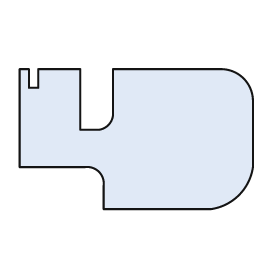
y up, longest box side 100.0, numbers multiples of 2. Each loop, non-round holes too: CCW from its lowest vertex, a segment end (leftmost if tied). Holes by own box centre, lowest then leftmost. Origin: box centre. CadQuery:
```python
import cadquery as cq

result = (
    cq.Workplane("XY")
    .moveTo(-14.0, -30.0)
    .lineTo(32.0, -30.0)
    .threePointArc((44.0, -24.0), (50.0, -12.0))
    .lineTo(50.0, 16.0)
    .threePointArc((46.0, 26.0), (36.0, 30.0))
    .lineTo(-10.0, 30.0)
    .lineTo(-10.0, 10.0)
    .threePointArc((-12.0, 6.0), (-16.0, 4.0))
    .lineTo(-24.0, 4.0)
    .lineTo(-24.0, 30.0)
    .lineTo(-42.0, 30.0)
    .lineTo(-42.0, 22.0)
    .lineTo(-46.0, 22.0)
    .lineTo(-46.0, 30.0)
    .lineTo(-50.0, 30.0)
    .lineTo(-50.0, -12.0)
    .lineTo(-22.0, -12.0)
    .threePointArc((-16.0, -14.0), (-14.0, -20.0))
    .close()
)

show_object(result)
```